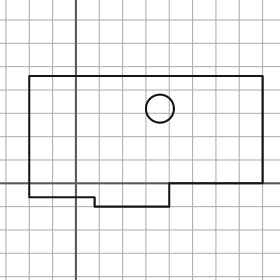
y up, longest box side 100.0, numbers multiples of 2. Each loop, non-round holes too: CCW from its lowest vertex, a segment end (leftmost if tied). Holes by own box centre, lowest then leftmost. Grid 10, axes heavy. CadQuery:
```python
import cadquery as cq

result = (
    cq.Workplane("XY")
    .moveTo(8.0, -10.0)
    .lineTo(40.0, -10.0)
    .lineTo(40.0, 0.0)
    .lineTo(80.0, 0.0)
    .lineTo(80.0, 46.0)
    .lineTo(-20.0, 46.0)
    .lineTo(-20.0, -6.0)
    .lineTo(8.0, -6.0)
    .close()
    .moveTo(36.0, 32.0)
    .circle(6.0)
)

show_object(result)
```